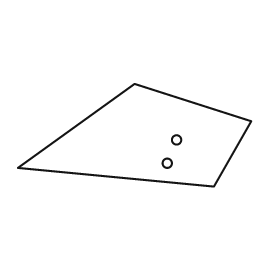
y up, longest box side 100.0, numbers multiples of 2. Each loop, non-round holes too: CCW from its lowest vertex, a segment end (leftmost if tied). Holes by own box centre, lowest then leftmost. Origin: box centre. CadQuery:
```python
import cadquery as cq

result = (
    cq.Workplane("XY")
    .moveTo(34.0, -22.0)
    .lineTo(50.0, 6.0)
    .lineTo(0.0, 22.0)
    .lineTo(-50.0, -14.0)
    .close()
    .moveTo(14.0, -12.0)
    .circle(2.0)
    .moveTo(18.0, -2.0)
    .circle(2.0)
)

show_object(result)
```